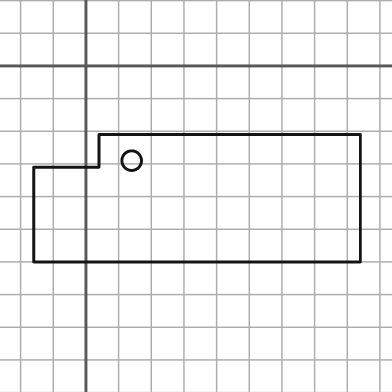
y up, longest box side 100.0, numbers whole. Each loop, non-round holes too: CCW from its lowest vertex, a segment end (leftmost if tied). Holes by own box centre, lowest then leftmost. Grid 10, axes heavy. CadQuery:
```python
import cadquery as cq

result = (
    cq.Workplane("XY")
    .moveTo(-16.0, -60.0)
    .lineTo(84.0, -60.0)
    .lineTo(84.0, -21.0)
    .lineTo(4.0, -21.0)
    .lineTo(4.0, -31.0)
    .lineTo(-16.0, -31.0)
    .close()
    .moveTo(14.0, -29.0)
    .circle(3.0)
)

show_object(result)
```